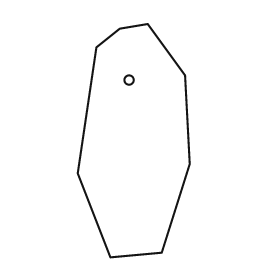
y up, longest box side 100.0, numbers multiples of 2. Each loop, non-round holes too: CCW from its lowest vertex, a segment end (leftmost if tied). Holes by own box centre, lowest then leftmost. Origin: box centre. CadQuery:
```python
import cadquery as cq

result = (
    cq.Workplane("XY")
    .moveTo(-10.0, -50.0)
    .lineTo(12.0, -48.0)
    .lineTo(24.0, -10.0)
    .lineTo(22.0, 28.0)
    .lineTo(6.0, 50.0)
    .lineTo(-6.0, 48.0)
    .lineTo(-16.0, 40.0)
    .lineTo(-24.0, -14.0)
    .close()
    .moveTo(-2.0, 26.0)
    .circle(2.0)
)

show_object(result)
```